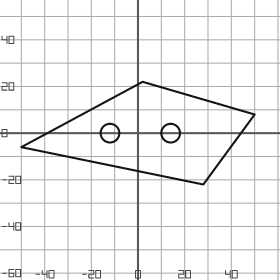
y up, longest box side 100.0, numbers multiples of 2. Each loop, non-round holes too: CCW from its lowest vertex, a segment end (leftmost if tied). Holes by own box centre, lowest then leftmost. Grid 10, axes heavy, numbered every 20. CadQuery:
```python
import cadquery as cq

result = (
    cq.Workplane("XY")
    .moveTo(28.0, -22.0)
    .lineTo(50.0, 8.0)
    .lineTo(2.0, 22.0)
    .lineTo(-50.0, -6.0)
    .close()
    .moveTo(-12.0, 0.0)
    .circle(4.0)
    .moveTo(14.0, 0.0)
    .circle(4.0)
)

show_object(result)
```